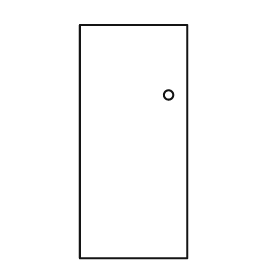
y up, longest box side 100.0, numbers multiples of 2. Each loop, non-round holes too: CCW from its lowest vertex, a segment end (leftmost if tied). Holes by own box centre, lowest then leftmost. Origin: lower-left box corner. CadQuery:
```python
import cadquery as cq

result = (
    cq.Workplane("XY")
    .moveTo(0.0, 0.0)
    .lineTo(46.0, 0.0)
    .lineTo(46.0, 100.0)
    .lineTo(0.0, 100.0)
    .close()
    .moveTo(38.0, 70.0)
    .circle(2.0)
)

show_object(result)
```